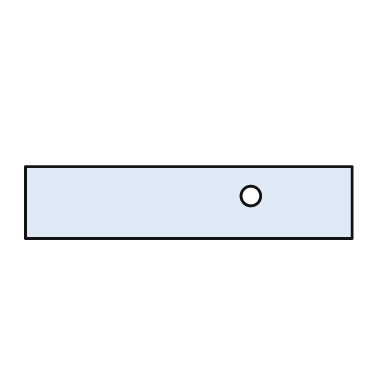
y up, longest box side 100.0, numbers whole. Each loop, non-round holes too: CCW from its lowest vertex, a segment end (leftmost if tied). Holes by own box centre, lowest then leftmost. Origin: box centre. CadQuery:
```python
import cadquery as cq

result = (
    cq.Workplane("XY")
    .moveTo(-50.0, -11.0)
    .lineTo(50.0, -11.0)
    .lineTo(50.0, 11.0)
    .lineTo(-50.0, 11.0)
    .close()
    .moveTo(19.0, 2.0)
    .circle(3.0)
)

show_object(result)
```